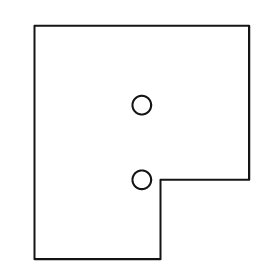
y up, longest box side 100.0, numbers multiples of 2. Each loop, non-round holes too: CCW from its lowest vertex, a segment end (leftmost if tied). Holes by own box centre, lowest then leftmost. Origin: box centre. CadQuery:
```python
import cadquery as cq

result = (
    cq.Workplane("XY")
    .moveTo(-46.0, -50.0)
    .lineTo(8.0, -50.0)
    .lineTo(8.0, -16.0)
    .lineTo(46.0, -16.0)
    .lineTo(46.0, 50.0)
    .lineTo(-46.0, 50.0)
    .close()
    .moveTo(0.0, -16.0)
    .circle(4.0)
    .moveTo(0.0, 16.0)
    .circle(4.0)
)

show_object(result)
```